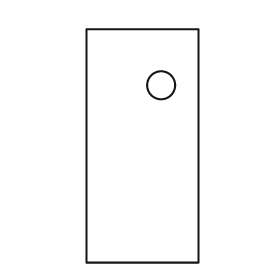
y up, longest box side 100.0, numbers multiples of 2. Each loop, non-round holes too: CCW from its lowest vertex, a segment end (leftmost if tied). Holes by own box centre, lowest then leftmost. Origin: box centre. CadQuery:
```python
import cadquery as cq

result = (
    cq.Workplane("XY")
    .moveTo(-24.0, -50.0)
    .lineTo(24.0, -50.0)
    .lineTo(24.0, 50.0)
    .lineTo(-24.0, 50.0)
    .close()
    .moveTo(8.0, 26.0)
    .circle(6.0)
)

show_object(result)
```